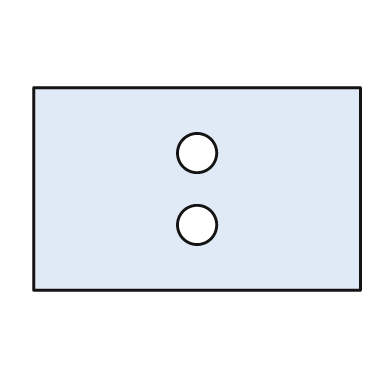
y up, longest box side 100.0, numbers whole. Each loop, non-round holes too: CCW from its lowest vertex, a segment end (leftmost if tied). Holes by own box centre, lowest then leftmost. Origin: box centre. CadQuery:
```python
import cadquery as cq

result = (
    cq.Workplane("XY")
    .moveTo(-50.0, -31.0)
    .lineTo(50.0, -31.0)
    .lineTo(50.0, 31.0)
    .lineTo(-50.0, 31.0)
    .close()
    .moveTo(0.0, -11.0)
    .circle(6.0)
    .moveTo(0.0, 11.0)
    .circle(6.0)
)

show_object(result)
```